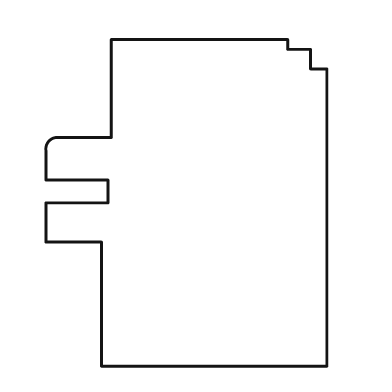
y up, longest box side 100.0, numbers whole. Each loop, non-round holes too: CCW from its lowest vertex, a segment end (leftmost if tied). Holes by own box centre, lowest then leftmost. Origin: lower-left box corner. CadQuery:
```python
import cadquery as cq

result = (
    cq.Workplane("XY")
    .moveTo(17.0, 0.0)
    .lineTo(86.0, 0.0)
    .lineTo(86.0, 91.0)
    .lineTo(81.0, 91.0)
    .lineTo(81.0, 97.0)
    .lineTo(74.0, 97.0)
    .lineTo(74.0, 100.0)
    .lineTo(20.0, 100.0)
    .lineTo(20.0, 70.0)
    .lineTo(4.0, 70.0)
    .threePointArc((1.0, 69.0), (0.0, 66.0))
    .lineTo(0.0, 57.0)
    .lineTo(19.0, 57.0)
    .lineTo(19.0, 50.0)
    .lineTo(0.0, 50.0)
    .lineTo(0.0, 38.0)
    .lineTo(17.0, 38.0)
    .close()
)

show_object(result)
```